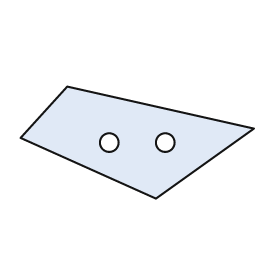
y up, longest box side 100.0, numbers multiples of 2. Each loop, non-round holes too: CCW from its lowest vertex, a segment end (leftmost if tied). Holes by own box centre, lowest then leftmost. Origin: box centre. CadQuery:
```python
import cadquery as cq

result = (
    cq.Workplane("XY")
    .moveTo(8.0, -24.0)
    .lineTo(50.0, 6.0)
    .lineTo(-30.0, 24.0)
    .lineTo(-50.0, 2.0)
    .close()
    .moveTo(-12.0, 0.0)
    .circle(4.0)
    .moveTo(12.0, 0.0)
    .circle(4.0)
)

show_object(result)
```